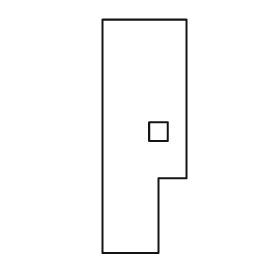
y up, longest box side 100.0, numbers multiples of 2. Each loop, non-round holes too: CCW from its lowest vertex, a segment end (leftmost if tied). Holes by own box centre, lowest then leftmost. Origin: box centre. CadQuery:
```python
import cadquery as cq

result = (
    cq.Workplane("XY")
    .moveTo(-18.0, -50.0)
    .lineTo(6.0, -50.0)
    .lineTo(6.0, -18.0)
    .lineTo(18.0, -18.0)
    .lineTo(18.0, 50.0)
    .lineTo(-18.0, 50.0)
    .close()
    .moveTo(2.0, -2.0)
    .lineTo(10.0, -2.0)
    .lineTo(10.0, 6.0)
    .lineTo(2.0, 6.0)
    .close()
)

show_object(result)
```